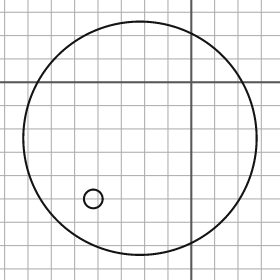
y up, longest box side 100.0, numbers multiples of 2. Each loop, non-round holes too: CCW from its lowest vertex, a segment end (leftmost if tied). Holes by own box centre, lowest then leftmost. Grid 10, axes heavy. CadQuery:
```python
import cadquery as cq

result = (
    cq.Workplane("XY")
    .moveTo(-22.0, -24.0)
    .circle(50.0)
    .moveTo(-42.0, -50.0)
    .circle(4.0)
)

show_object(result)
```